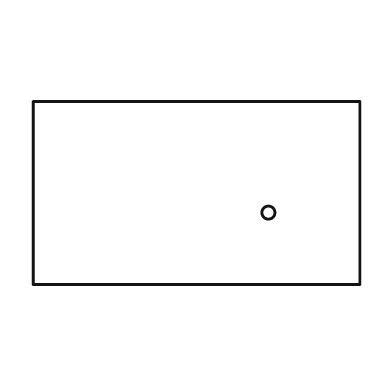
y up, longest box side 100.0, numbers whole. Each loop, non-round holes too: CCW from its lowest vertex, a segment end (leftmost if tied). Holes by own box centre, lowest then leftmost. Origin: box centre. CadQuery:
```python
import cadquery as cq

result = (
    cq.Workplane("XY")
    .moveTo(-50.0, -28.0)
    .lineTo(50.0, -28.0)
    .lineTo(50.0, 28.0)
    .lineTo(-50.0, 28.0)
    .close()
    .moveTo(22.0, -6.0)
    .circle(2.0)
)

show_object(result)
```